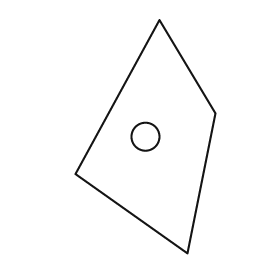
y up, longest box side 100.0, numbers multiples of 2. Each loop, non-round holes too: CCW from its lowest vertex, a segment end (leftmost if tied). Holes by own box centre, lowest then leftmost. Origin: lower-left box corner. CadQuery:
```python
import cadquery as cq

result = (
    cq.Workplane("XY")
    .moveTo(48.0, 0.0)
    .lineTo(60.0, 60.0)
    .lineTo(36.0, 100.0)
    .lineTo(0.0, 34.0)
    .close()
    .moveTo(30.0, 50.0)
    .circle(6.0)
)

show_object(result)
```